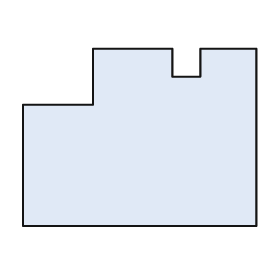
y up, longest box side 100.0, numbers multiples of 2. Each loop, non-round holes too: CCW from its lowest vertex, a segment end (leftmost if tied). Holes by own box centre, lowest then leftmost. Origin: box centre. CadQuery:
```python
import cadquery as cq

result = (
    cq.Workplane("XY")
    .moveTo(-50.0, -38.0)
    .lineTo(50.0, -38.0)
    .lineTo(50.0, 38.0)
    .lineTo(26.0, 38.0)
    .lineTo(26.0, 26.0)
    .lineTo(14.0, 26.0)
    .lineTo(14.0, 38.0)
    .lineTo(-20.0, 38.0)
    .lineTo(-20.0, 14.0)
    .lineTo(-50.0, 14.0)
    .close()
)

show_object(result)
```